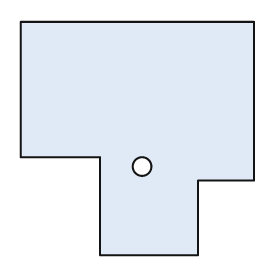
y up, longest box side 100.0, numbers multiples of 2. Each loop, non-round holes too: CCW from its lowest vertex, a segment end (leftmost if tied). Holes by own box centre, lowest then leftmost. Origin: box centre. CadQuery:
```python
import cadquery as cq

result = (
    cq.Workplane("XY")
    .moveTo(-16.0, -50.0)
    .lineTo(26.0, -50.0)
    .lineTo(26.0, -18.0)
    .lineTo(50.0, -18.0)
    .lineTo(50.0, 50.0)
    .lineTo(-50.0, 50.0)
    .lineTo(-50.0, -8.0)
    .lineTo(-16.0, -8.0)
    .close()
    .moveTo(2.0, -12.0)
    .circle(4.0)
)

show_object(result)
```